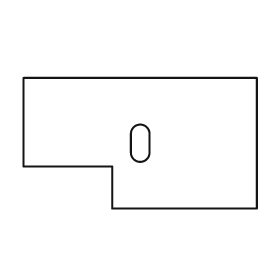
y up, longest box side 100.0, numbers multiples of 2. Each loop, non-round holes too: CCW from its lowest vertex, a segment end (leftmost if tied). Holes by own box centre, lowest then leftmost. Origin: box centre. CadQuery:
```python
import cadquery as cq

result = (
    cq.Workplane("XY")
    .moveTo(-12.0, -28.0)
    .lineTo(50.0, -28.0)
    .lineTo(50.0, 28.0)
    .lineTo(-50.0, 28.0)
    .lineTo(-50.0, -10.0)
    .lineTo(-12.0, -10.0)
    .close()
    .moveTo(-4.0, -4.0)
    .threePointArc((0.0, -8.0), (4.0, -4.0))
    .lineTo(4.0, 4.0)
    .threePointArc((0.0, 8.0), (-4.0, 4.0))
    .close()
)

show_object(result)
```